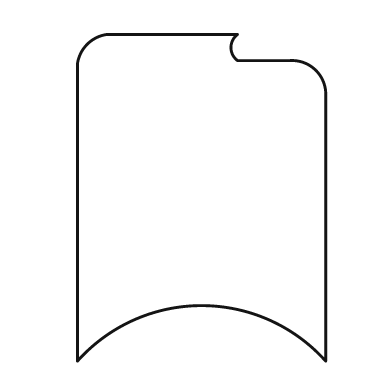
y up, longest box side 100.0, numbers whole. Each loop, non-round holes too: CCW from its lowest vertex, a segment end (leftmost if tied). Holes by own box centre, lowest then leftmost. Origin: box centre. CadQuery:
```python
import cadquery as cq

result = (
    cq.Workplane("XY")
    .moveTo(-38.0, -50.0)
    .threePointArc((0.0, -33.0), (38.0, -50.0))
    .lineTo(38.0, 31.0)
    .threePointArc((35.0, 39.0), (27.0, 42.0))
    .lineTo(11.0, 42.0)
    .threePointArc((9.0, 46.0), (11.0, 50.0))
    .lineTo(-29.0, 50.0)
    .threePointArc((-35.0, 47.0), (-38.0, 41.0))
    .close()
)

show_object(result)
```